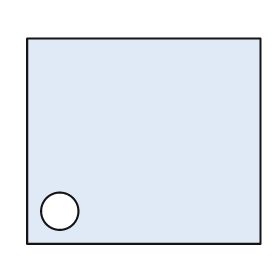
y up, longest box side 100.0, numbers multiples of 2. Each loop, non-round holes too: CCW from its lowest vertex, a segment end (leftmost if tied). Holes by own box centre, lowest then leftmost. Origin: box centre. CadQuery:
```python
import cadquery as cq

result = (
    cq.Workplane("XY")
    .moveTo(-50.0, -44.0)
    .lineTo(50.0, -44.0)
    .lineTo(50.0, 44.0)
    .lineTo(-50.0, 44.0)
    .close()
    .moveTo(-36.0, -30.0)
    .circle(8.0)
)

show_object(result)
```